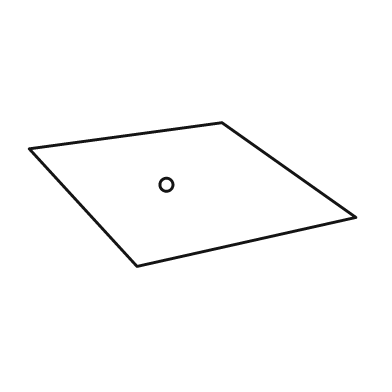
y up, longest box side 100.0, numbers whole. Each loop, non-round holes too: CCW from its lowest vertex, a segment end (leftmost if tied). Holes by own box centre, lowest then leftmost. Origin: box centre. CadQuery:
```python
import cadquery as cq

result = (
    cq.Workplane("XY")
    .moveTo(-17.0, -22.0)
    .lineTo(50.0, -7.0)
    .lineTo(9.0, 22.0)
    .lineTo(-50.0, 14.0)
    .close()
    .moveTo(-8.0, 3.0)
    .circle(2.0)
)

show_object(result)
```